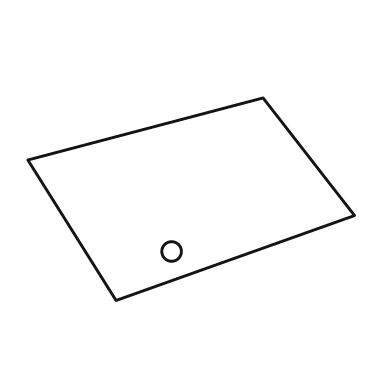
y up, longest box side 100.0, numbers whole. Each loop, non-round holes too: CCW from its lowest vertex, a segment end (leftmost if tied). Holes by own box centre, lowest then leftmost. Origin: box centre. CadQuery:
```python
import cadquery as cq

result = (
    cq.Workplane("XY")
    .moveTo(-23.0, -31.0)
    .lineTo(50.0, -5.0)
    .lineTo(22.0, 31.0)
    .lineTo(-50.0, 12.0)
    .close()
    .moveTo(-6.0, -16.0)
    .circle(3.0)
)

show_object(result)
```